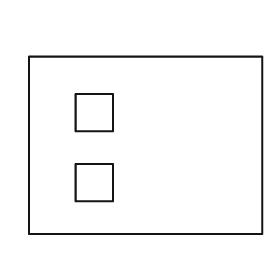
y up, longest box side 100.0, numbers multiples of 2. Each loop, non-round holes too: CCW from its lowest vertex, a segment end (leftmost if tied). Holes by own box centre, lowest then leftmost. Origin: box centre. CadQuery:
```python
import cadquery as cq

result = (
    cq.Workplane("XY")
    .moveTo(-50.0, -38.0)
    .lineTo(50.0, -38.0)
    .lineTo(50.0, 38.0)
    .lineTo(-50.0, 38.0)
    .close()
    .moveTo(-30.0, -24.0)
    .lineTo(-14.0, -24.0)
    .lineTo(-14.0, -8.0)
    .lineTo(-30.0, -8.0)
    .close()
    .moveTo(-30.0, 6.0)
    .lineTo(-14.0, 6.0)
    .lineTo(-14.0, 22.0)
    .lineTo(-30.0, 22.0)
    .close()
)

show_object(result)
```